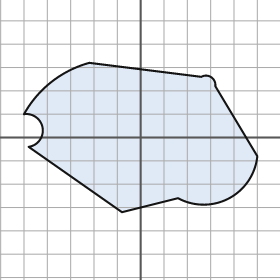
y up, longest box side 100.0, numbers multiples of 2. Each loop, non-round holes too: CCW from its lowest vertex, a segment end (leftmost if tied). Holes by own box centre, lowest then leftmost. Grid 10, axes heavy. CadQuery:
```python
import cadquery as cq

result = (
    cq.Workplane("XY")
    .moveTo(-8.0, -32.0)
    .lineTo(16.0, -26.0)
    .threePointArc((38.0, -26.0), (50.0, -8.0))
    .lineTo(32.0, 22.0)
    .threePointArc((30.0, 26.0), (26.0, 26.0))
    .lineTo(-22.0, 32.0)
    .threePointArc((-38.0, 24.0), (-50.0, 10.0))
    .threePointArc((-42.0, 4.0), (-48.0, -4.0))
    .close()
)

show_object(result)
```